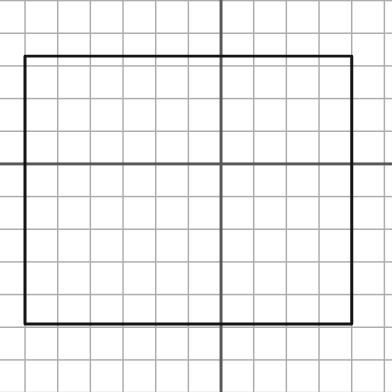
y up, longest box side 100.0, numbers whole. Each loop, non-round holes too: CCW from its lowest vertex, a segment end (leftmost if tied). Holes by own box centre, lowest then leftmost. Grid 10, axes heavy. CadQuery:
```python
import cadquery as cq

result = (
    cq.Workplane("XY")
    .moveTo(-60.0, -49.0)
    .lineTo(40.0, -49.0)
    .lineTo(40.0, 33.0)
    .lineTo(-60.0, 33.0)
    .close()
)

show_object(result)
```